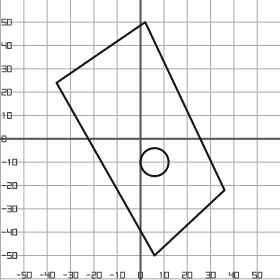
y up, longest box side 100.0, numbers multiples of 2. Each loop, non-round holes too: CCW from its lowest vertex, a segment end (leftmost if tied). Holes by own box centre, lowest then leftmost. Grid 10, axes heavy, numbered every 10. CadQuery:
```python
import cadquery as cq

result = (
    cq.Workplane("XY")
    .moveTo(6.0, -50.0)
    .lineTo(36.0, -22.0)
    .lineTo(2.0, 50.0)
    .lineTo(-36.0, 24.0)
    .close()
    .moveTo(6.0, -10.0)
    .circle(6.0)
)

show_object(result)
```